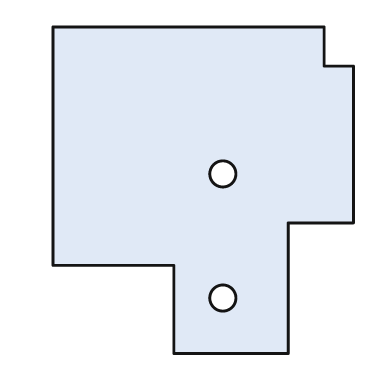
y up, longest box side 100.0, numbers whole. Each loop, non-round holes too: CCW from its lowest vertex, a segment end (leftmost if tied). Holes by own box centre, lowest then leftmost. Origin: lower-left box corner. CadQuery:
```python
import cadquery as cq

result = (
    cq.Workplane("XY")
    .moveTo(37.0, 0.0)
    .lineTo(72.0, 0.0)
    .lineTo(72.0, 40.0)
    .lineTo(92.0, 40.0)
    .lineTo(92.0, 88.0)
    .lineTo(83.0, 88.0)
    .lineTo(83.0, 100.0)
    .lineTo(0.0, 100.0)
    .lineTo(0.0, 27.0)
    .lineTo(37.0, 27.0)
    .close()
    .moveTo(52.0, 17.0)
    .circle(4.0)
    .moveTo(52.0, 55.0)
    .circle(4.0)
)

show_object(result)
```